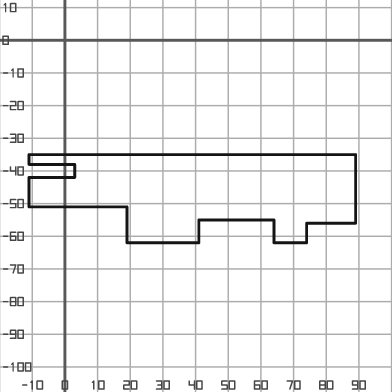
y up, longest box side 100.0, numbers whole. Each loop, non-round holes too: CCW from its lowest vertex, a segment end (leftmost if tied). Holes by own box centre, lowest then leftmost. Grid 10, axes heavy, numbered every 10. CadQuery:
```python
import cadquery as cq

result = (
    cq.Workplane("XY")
    .moveTo(19.0, -62.0)
    .lineTo(41.0, -62.0)
    .lineTo(41.0, -55.0)
    .lineTo(64.0, -55.0)
    .lineTo(64.0, -62.0)
    .lineTo(74.0, -62.0)
    .lineTo(74.0, -56.0)
    .lineTo(89.0, -56.0)
    .lineTo(89.0, -35.0)
    .lineTo(-11.0, -35.0)
    .lineTo(-11.0, -38.0)
    .lineTo(3.0, -38.0)
    .lineTo(3.0, -42.0)
    .lineTo(-11.0, -42.0)
    .lineTo(-11.0, -51.0)
    .lineTo(19.0, -51.0)
    .close()
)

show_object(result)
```